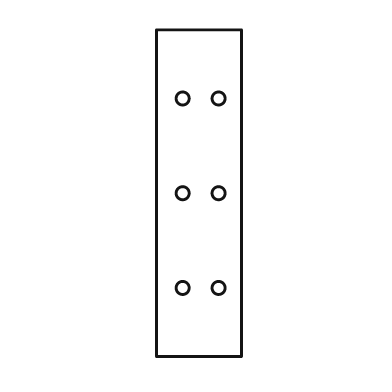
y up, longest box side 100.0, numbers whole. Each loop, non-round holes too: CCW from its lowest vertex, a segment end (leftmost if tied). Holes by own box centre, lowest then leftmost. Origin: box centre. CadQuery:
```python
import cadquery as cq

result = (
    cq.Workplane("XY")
    .moveTo(-13.0, -50.0)
    .lineTo(13.0, -50.0)
    .lineTo(13.0, 50.0)
    .lineTo(-13.0, 50.0)
    .close()
    .moveTo(-5.0, -29.0)
    .circle(2.0)
    .moveTo(6.0, -29.0)
    .circle(2.0)
    .moveTo(-5.0, 0.0)
    .circle(2.0)
    .moveTo(6.0, 0.0)
    .circle(2.0)
    .moveTo(-5.0, 29.0)
    .circle(2.0)
    .moveTo(6.0, 29.0)
    .circle(2.0)
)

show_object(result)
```